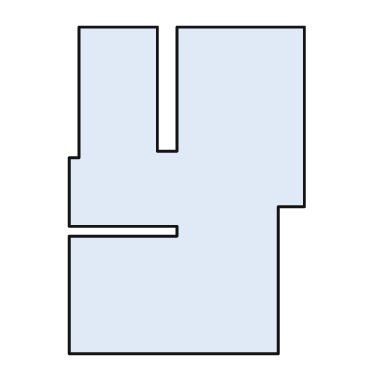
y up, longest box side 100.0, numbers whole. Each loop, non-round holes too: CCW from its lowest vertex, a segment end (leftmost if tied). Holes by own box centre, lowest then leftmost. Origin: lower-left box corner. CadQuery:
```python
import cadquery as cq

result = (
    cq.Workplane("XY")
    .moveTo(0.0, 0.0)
    .lineTo(64.0, 0.0)
    .lineTo(64.0, 45.0)
    .lineTo(72.0, 45.0)
    .lineTo(72.0, 100.0)
    .lineTo(33.0, 100.0)
    .lineTo(33.0, 62.0)
    .lineTo(27.0, 62.0)
    .lineTo(27.0, 100.0)
    .lineTo(3.0, 100.0)
    .lineTo(3.0, 60.0)
    .lineTo(0.0, 60.0)
    .lineTo(0.0, 39.0)
    .lineTo(33.0, 39.0)
    .lineTo(33.0, 36.0)
    .lineTo(0.0, 36.0)
    .close()
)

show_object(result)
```